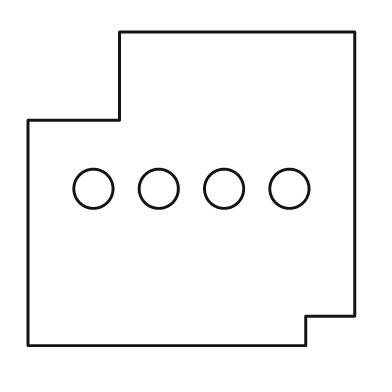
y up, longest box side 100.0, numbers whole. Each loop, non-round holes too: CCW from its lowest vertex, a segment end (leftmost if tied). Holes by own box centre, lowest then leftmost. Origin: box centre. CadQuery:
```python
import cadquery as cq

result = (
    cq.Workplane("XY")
    .moveTo(-50.0, -48.0)
    .lineTo(35.0, -48.0)
    .lineTo(35.0, -39.0)
    .lineTo(50.0, -39.0)
    .lineTo(50.0, 48.0)
    .lineTo(-22.0, 48.0)
    .lineTo(-22.0, 21.0)
    .lineTo(-50.0, 21.0)
    .close()
    .moveTo(-30.0, 0.0)
    .circle(6.0)
    .moveTo(-10.0, 0.0)
    .circle(6.0)
    .moveTo(10.0, 0.0)
    .circle(6.0)
    .moveTo(30.0, 0.0)
    .circle(6.0)
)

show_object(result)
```